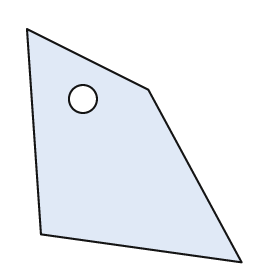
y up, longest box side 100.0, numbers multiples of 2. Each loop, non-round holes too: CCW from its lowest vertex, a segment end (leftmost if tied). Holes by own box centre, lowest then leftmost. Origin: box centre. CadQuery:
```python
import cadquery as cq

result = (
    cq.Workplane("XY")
    .moveTo(46.0, -50.0)
    .lineTo(6.0, 24.0)
    .lineTo(-46.0, 50.0)
    .lineTo(-40.0, -38.0)
    .close()
    .moveTo(-22.0, 20.0)
    .circle(6.0)
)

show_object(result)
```